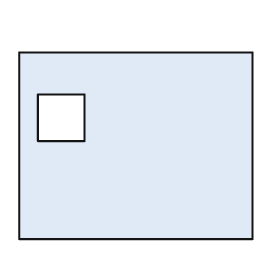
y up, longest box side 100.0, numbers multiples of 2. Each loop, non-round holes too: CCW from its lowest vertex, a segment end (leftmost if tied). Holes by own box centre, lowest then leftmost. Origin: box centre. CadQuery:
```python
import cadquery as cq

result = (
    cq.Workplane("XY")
    .moveTo(-50.0, -40.0)
    .lineTo(50.0, -40.0)
    .lineTo(50.0, 40.0)
    .lineTo(-50.0, 40.0)
    .close()
    .moveTo(-42.0, 2.0)
    .lineTo(-22.0, 2.0)
    .lineTo(-22.0, 22.0)
    .lineTo(-42.0, 22.0)
    .close()
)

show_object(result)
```